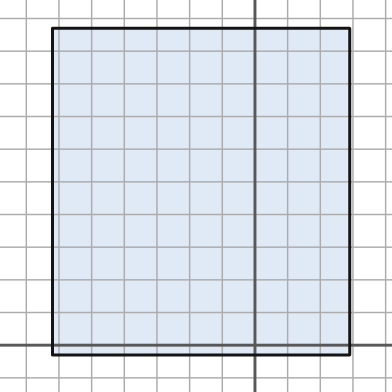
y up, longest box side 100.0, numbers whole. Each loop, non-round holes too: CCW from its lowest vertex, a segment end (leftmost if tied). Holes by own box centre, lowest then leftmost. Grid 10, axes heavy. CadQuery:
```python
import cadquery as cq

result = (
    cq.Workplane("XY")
    .moveTo(-62.0, -3.0)
    .lineTo(29.0, -3.0)
    .lineTo(29.0, 97.0)
    .lineTo(-62.0, 97.0)
    .close()
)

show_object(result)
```